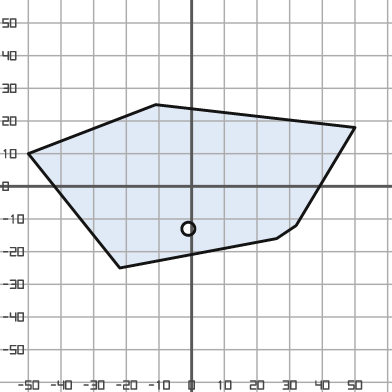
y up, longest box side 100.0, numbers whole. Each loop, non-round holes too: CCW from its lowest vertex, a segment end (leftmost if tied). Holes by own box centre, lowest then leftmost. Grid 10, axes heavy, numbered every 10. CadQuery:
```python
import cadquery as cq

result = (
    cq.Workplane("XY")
    .moveTo(-22.0, -25.0)
    .lineTo(26.0, -16.0)
    .lineTo(32.0, -12.0)
    .lineTo(50.0, 18.0)
    .lineTo(-11.0, 25.0)
    .lineTo(-50.0, 10.0)
    .close()
    .moveTo(-1.0, -13.0)
    .circle(2.0)
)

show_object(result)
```